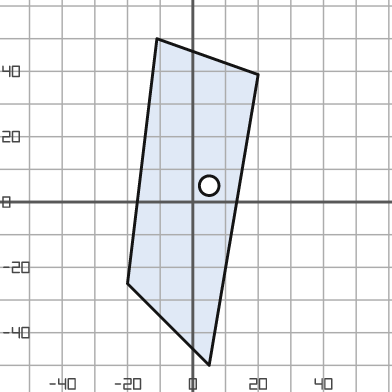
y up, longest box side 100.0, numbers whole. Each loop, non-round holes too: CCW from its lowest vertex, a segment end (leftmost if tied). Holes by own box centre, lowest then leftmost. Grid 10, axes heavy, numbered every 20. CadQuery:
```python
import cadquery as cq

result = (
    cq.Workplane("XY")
    .moveTo(5.0, -50.0)
    .lineTo(20.0, 39.0)
    .lineTo(-11.0, 50.0)
    .lineTo(-20.0, -25.0)
    .close()
    .moveTo(5.0, 5.0)
    .circle(3.0)
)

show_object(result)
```